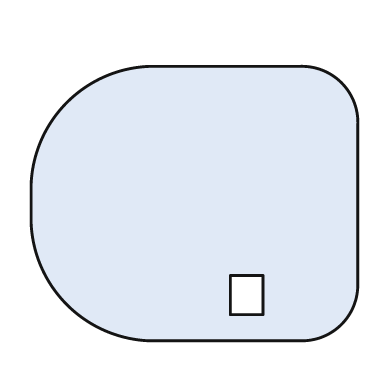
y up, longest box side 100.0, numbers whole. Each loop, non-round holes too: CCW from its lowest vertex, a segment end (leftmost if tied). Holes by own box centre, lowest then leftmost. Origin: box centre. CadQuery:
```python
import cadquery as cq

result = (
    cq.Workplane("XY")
    .moveTo(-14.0, -42.0)
    .lineTo(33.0, -42.0)
    .threePointArc((45.0, -37.0), (50.0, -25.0))
    .lineTo(50.0, 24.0)
    .threePointArc((45.0, 37.0), (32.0, 42.0))
    .lineTo(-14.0, 42.0)
    .threePointArc((-39.0, 31.0), (-50.0, 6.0))
    .lineTo(-50.0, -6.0)
    .threePointArc((-39.0, -31.0), (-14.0, -42.0))
    .close()
    .moveTo(11.0, -34.0)
    .lineTo(21.0, -34.0)
    .lineTo(21.0, -22.0)
    .lineTo(11.0, -22.0)
    .close()
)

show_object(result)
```